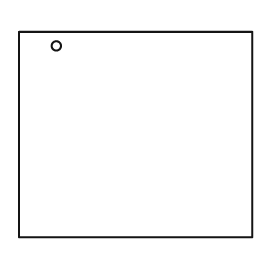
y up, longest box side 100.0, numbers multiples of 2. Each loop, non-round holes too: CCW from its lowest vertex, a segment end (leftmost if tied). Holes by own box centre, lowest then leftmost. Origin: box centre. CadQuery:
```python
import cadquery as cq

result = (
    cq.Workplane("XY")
    .moveTo(-50.0, -44.0)
    .lineTo(50.0, -44.0)
    .lineTo(50.0, 44.0)
    .lineTo(-50.0, 44.0)
    .close()
    .moveTo(-34.0, 38.0)
    .circle(2.0)
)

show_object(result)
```